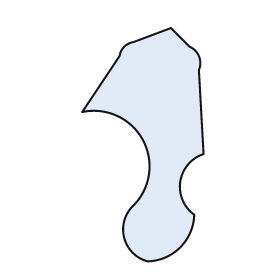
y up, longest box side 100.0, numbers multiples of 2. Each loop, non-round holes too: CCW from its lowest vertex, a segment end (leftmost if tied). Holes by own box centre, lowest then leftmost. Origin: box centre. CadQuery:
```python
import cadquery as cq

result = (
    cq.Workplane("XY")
    .moveTo(2.0, -50.0)
    .threePointArc((16.0, -44.0), (22.0, -30.0))
    .threePointArc((16.0, -16.0), (26.0, -4.0))
    .lineTo(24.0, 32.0)
    .threePointArc((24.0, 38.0), (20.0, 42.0))
    .lineTo(12.0, 50.0)
    .lineTo(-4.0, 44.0)
    .threePointArc((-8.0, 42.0), (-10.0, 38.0))
    .lineTo(-26.0, 14.0)
    .threePointArc((0.0, 2.0), (-4.0, -26.0))
    .threePointArc((-8.0, -40.0), (2.0, -50.0))
    .close()
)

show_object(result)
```